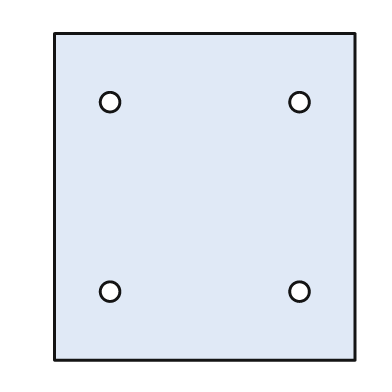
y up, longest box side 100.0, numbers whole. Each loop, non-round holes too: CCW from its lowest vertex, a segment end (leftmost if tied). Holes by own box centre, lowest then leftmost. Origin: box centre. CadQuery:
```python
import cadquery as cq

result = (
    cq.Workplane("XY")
    .moveTo(-46.0, -50.0)
    .lineTo(46.0, -50.0)
    .lineTo(46.0, 50.0)
    .lineTo(-46.0, 50.0)
    .close()
    .moveTo(-29.0, -29.0)
    .circle(3.0)
    .moveTo(29.0, -29.0)
    .circle(3.0)
    .moveTo(-29.0, 29.0)
    .circle(3.0)
    .moveTo(29.0, 29.0)
    .circle(3.0)
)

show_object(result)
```